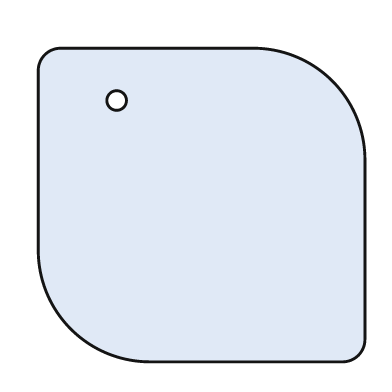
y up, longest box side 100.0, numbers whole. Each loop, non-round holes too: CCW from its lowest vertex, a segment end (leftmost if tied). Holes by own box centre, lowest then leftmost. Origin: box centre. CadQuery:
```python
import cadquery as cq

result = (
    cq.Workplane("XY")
    .moveTo(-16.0, -48.0)
    .lineTo(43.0, -48.0)
    .threePointArc((48.0, -46.0), (50.0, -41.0))
    .lineTo(50.0, 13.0)
    .threePointArc((40.0, 38.0), (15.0, 48.0))
    .lineTo(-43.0, 48.0)
    .threePointArc((-48.0, 46.0), (-50.0, 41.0))
    .lineTo(-50.0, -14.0)
    .threePointArc((-40.0, -38.0), (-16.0, -48.0))
    .close()
    .moveTo(-26.0, 32.0)
    .circle(3.0)
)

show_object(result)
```